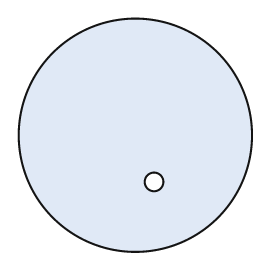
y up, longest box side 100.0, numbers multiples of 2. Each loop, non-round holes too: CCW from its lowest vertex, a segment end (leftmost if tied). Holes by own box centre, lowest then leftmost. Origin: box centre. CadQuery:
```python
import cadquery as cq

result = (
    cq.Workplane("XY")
    .moveTo(0.0, 0.0)
    .circle(50.0)
    .moveTo(8.0, -20.0)
    .circle(4.0)
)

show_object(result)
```